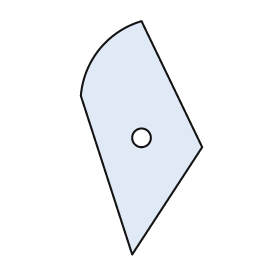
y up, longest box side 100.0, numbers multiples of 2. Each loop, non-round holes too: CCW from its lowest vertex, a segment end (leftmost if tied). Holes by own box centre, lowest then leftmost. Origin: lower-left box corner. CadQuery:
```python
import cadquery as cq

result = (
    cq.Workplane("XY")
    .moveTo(22.0, 0.0)
    .lineTo(52.0, 46.0)
    .lineTo(26.0, 100.0)
    .threePointArc((8.0, 88.0), (0.0, 68.0))
    .close()
    .moveTo(26.0, 50.0)
    .circle(4.0)
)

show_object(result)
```